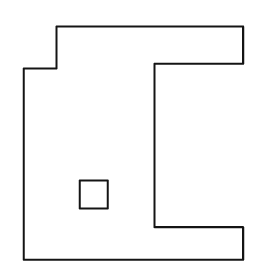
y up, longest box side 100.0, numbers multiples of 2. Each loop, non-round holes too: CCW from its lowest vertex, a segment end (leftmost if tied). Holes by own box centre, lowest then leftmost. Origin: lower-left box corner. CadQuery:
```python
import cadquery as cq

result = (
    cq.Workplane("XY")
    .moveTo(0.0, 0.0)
    .lineTo(94.0, 0.0)
    .lineTo(94.0, 14.0)
    .lineTo(56.0, 14.0)
    .lineTo(56.0, 84.0)
    .lineTo(94.0, 84.0)
    .lineTo(94.0, 100.0)
    .lineTo(14.0, 100.0)
    .lineTo(14.0, 82.0)
    .lineTo(0.0, 82.0)
    .close()
    .moveTo(24.0, 22.0)
    .lineTo(36.0, 22.0)
    .lineTo(36.0, 34.0)
    .lineTo(24.0, 34.0)
    .close()
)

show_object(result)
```